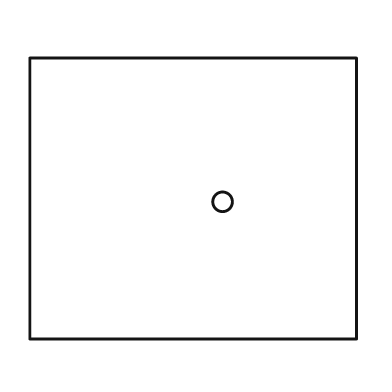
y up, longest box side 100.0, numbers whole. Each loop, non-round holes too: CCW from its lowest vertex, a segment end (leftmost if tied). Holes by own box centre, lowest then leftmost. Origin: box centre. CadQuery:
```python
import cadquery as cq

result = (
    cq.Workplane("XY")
    .moveTo(-50.0, -43.0)
    .lineTo(50.0, -43.0)
    .lineTo(50.0, 43.0)
    .lineTo(-50.0, 43.0)
    .close()
    .moveTo(9.0, -1.0)
    .circle(3.0)
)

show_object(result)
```